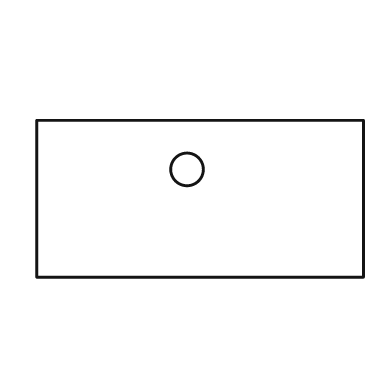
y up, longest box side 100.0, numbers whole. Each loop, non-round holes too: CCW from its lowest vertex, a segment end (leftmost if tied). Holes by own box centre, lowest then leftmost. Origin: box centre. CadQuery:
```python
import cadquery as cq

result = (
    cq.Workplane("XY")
    .moveTo(-50.0, -24.0)
    .lineTo(50.0, -24.0)
    .lineTo(50.0, 24.0)
    .lineTo(-50.0, 24.0)
    .close()
    .moveTo(-4.0, 9.0)
    .circle(5.0)
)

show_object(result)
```